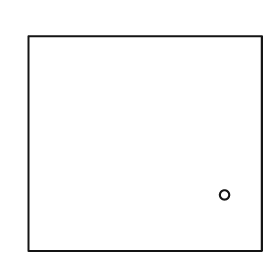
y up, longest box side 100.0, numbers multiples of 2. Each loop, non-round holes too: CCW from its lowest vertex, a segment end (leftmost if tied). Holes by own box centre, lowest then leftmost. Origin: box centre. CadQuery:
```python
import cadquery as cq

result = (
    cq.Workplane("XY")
    .moveTo(-50.0, -46.0)
    .lineTo(50.0, -46.0)
    .lineTo(50.0, 46.0)
    .lineTo(-50.0, 46.0)
    .close()
    .moveTo(34.0, -22.0)
    .circle(2.0)
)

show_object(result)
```